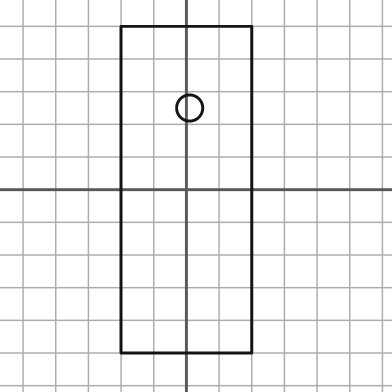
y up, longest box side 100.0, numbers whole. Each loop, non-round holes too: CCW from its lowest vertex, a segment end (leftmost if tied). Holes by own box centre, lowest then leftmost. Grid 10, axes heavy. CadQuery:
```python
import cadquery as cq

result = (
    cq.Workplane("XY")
    .moveTo(-20.0, -50.0)
    .lineTo(20.0, -50.0)
    .lineTo(20.0, 50.0)
    .lineTo(-20.0, 50.0)
    .close()
    .moveTo(1.0, 25.0)
    .circle(4.0)
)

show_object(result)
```